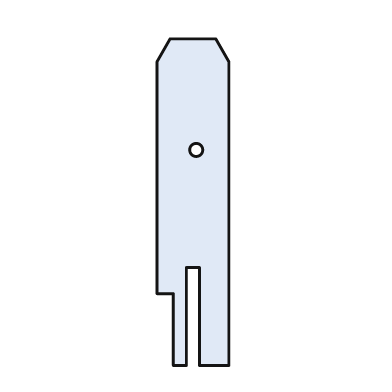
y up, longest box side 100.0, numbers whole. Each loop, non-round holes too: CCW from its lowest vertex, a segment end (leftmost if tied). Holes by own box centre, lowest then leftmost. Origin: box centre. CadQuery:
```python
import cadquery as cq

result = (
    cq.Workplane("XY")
    .moveTo(-6.0, -50.0)
    .lineTo(-2.0, -50.0)
    .lineTo(-2.0, -20.0)
    .lineTo(2.0, -20.0)
    .lineTo(2.0, -50.0)
    .lineTo(11.0, -50.0)
    .lineTo(11.0, 43.0)
    .lineTo(7.0, 50.0)
    .lineTo(-7.0, 50.0)
    .lineTo(-11.0, 43.0)
    .lineTo(-11.0, -28.0)
    .lineTo(-6.0, -28.0)
    .close()
    .moveTo(1.0, 16.0)
    .circle(2.0)
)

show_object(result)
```